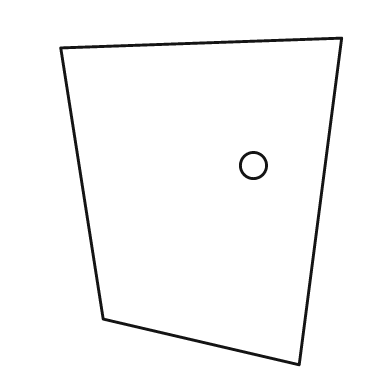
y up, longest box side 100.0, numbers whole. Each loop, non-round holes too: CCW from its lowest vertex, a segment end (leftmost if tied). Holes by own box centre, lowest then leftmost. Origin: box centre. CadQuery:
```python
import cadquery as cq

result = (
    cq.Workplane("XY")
    .moveTo(30.0, -50.0)
    .lineTo(43.0, 50.0)
    .lineTo(-43.0, 47.0)
    .lineTo(-30.0, -36.0)
    .close()
    .moveTo(16.0, 11.0)
    .circle(4.0)
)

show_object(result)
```